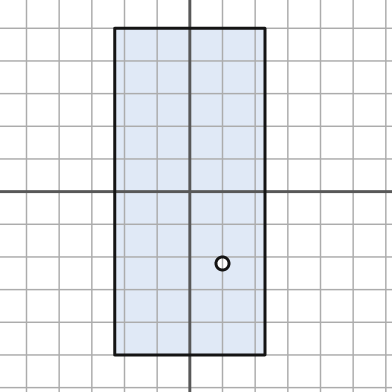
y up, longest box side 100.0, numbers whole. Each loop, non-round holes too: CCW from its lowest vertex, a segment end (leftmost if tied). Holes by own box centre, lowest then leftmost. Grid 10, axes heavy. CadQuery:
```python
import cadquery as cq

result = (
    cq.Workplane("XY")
    .moveTo(-23.0, -50.0)
    .lineTo(23.0, -50.0)
    .lineTo(23.0, 50.0)
    .lineTo(-23.0, 50.0)
    .close()
    .moveTo(10.0, -22.0)
    .circle(2.0)
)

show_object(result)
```